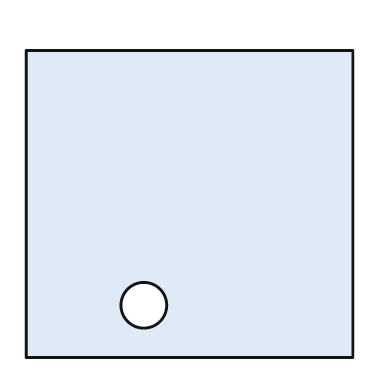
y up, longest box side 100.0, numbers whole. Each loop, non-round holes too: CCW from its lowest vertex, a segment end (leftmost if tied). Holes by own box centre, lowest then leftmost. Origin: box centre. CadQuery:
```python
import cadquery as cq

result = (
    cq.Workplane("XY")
    .moveTo(-50.0, -47.0)
    .lineTo(50.0, -47.0)
    .lineTo(50.0, 47.0)
    .lineTo(-50.0, 47.0)
    .close()
    .moveTo(-14.0, -31.0)
    .circle(7.0)
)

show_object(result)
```